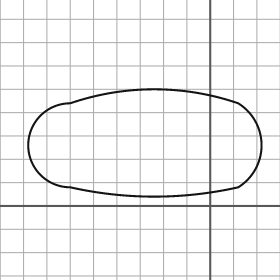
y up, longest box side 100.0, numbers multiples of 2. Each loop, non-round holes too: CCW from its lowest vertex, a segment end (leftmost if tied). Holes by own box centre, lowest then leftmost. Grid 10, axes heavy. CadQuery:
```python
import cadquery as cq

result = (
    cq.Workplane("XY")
    .moveTo(-60.0, 8.0)
    .threePointArc((-24.0, 4.0), (12.0, 8.0))
    .threePointArc((22.0, 26.0), (12.0, 44.0))
    .threePointArc((-24.0, 50.0), (-60.0, 44.0))
    .threePointArc((-78.0, 26.0), (-60.0, 8.0))
    .close()
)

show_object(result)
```